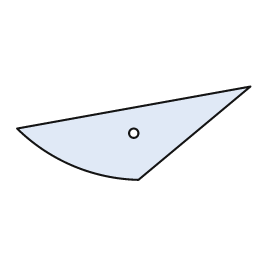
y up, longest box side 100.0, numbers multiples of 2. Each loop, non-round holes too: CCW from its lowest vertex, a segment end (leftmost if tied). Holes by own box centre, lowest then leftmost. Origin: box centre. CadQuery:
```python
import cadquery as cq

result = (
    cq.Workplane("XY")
    .moveTo(2.0, -20.0)
    .lineTo(50.0, 20.0)
    .lineTo(-50.0, 2.0)
    .threePointArc((-26.0, -14.0), (2.0, -20.0))
    .close()
    .moveTo(0.0, 0.0)
    .circle(2.0)
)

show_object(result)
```